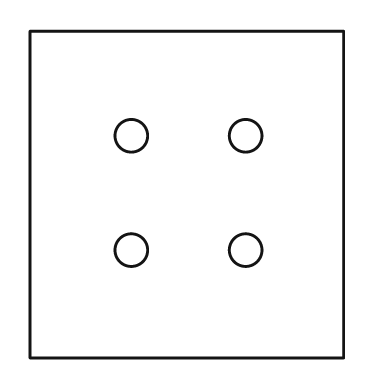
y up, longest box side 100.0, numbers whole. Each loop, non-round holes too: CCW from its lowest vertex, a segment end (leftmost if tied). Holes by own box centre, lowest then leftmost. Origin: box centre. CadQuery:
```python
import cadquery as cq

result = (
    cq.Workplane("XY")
    .moveTo(-48.0, -50.0)
    .lineTo(48.0, -50.0)
    .lineTo(48.0, 50.0)
    .lineTo(-48.0, 50.0)
    .close()
    .moveTo(-17.0, -17.0)
    .circle(5.0)
    .moveTo(18.0, -17.0)
    .circle(5.0)
    .moveTo(-17.0, 18.0)
    .circle(5.0)
    .moveTo(18.0, 18.0)
    .circle(5.0)
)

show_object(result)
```